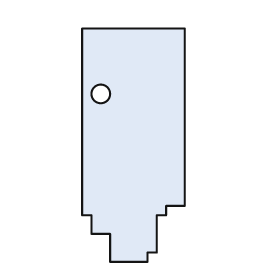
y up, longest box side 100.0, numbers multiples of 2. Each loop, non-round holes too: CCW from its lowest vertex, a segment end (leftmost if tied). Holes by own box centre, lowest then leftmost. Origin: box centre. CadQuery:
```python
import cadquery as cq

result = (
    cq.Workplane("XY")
    .moveTo(-10.0, -50.0)
    .lineTo(6.0, -50.0)
    .lineTo(6.0, -46.0)
    .lineTo(10.0, -46.0)
    .lineTo(10.0, -30.0)
    .lineTo(14.0, -30.0)
    .lineTo(14.0, -26.0)
    .lineTo(22.0, -26.0)
    .lineTo(22.0, 50.0)
    .lineTo(-22.0, 50.0)
    .lineTo(-22.0, -30.0)
    .lineTo(-18.0, -30.0)
    .lineTo(-18.0, -38.0)
    .lineTo(-10.0, -38.0)
    .close()
    .moveTo(-14.0, 22.0)
    .circle(4.0)
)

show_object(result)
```